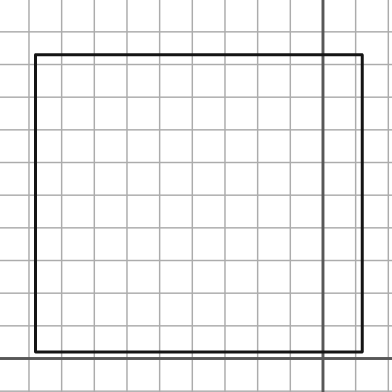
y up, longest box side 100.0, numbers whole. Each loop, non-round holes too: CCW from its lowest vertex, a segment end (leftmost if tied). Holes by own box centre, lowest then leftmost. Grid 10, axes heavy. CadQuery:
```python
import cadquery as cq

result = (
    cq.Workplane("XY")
    .moveTo(-88.0, 2.0)
    .lineTo(12.0, 2.0)
    .lineTo(12.0, 93.0)
    .lineTo(-88.0, 93.0)
    .close()
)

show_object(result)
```